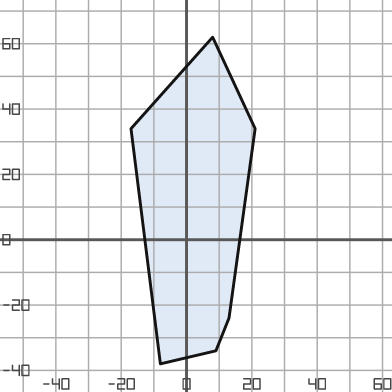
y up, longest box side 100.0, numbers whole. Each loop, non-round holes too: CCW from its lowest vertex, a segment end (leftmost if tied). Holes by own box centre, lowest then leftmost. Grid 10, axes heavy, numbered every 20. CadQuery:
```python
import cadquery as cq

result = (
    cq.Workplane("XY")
    .moveTo(-8.0, -38.0)
    .lineTo(9.0, -34.0)
    .lineTo(13.0, -24.0)
    .lineTo(21.0, 34.0)
    .lineTo(8.0, 62.0)
    .lineTo(-17.0, 34.0)
    .close()
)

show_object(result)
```